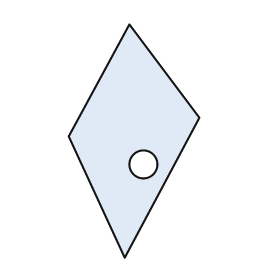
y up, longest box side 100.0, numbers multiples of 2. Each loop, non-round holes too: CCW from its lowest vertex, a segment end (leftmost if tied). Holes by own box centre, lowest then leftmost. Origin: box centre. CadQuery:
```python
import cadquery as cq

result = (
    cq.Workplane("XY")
    .moveTo(-4.0, -50.0)
    .lineTo(28.0, 10.0)
    .lineTo(-2.0, 50.0)
    .lineTo(-28.0, 2.0)
    .close()
    .moveTo(4.0, -10.0)
    .circle(6.0)
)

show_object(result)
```